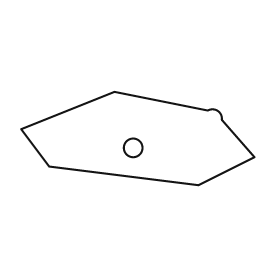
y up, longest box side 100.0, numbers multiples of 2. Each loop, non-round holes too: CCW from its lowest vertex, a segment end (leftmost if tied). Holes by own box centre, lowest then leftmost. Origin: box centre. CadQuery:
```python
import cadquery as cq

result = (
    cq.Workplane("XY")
    .moveTo(26.0, -20.0)
    .lineTo(50.0, -8.0)
    .lineTo(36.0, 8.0)
    .threePointArc((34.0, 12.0), (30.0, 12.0))
    .lineTo(-10.0, 20.0)
    .lineTo(-50.0, 4.0)
    .lineTo(-38.0, -12.0)
    .close()
    .moveTo(-2.0, -4.0)
    .circle(4.0)
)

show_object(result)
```